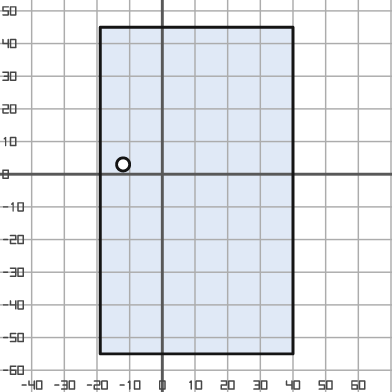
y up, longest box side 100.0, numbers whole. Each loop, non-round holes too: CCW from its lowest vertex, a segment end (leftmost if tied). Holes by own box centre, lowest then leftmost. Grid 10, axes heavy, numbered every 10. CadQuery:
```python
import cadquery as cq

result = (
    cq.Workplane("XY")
    .moveTo(-19.0, -55.0)
    .lineTo(40.0, -55.0)
    .lineTo(40.0, 45.0)
    .lineTo(-19.0, 45.0)
    .close()
    .moveTo(-12.0, 3.0)
    .circle(2.0)
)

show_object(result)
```